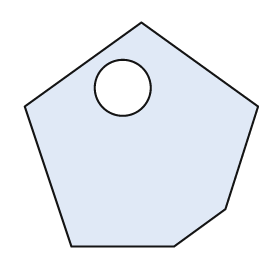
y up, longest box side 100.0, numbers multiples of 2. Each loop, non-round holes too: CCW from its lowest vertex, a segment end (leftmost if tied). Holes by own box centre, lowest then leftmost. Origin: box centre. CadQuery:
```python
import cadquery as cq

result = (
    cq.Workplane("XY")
    .moveTo(-30.0, -48.0)
    .lineTo(14.0, -48.0)
    .lineTo(36.0, -32.0)
    .lineTo(50.0, 12.0)
    .lineTo(0.0, 48.0)
    .lineTo(-50.0, 12.0)
    .close()
    .moveTo(-8.0, 20.0)
    .circle(12.0)
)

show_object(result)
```